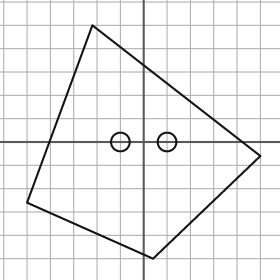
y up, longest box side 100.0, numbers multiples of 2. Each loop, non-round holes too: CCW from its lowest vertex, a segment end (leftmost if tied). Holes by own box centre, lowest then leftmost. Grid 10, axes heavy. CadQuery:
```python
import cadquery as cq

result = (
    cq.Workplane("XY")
    .moveTo(4.0, -50.0)
    .lineTo(50.0, -6.0)
    .lineTo(-22.0, 50.0)
    .lineTo(-50.0, -26.0)
    .close()
    .moveTo(-10.0, 0.0)
    .circle(4.0)
    .moveTo(10.0, 0.0)
    .circle(4.0)
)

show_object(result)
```